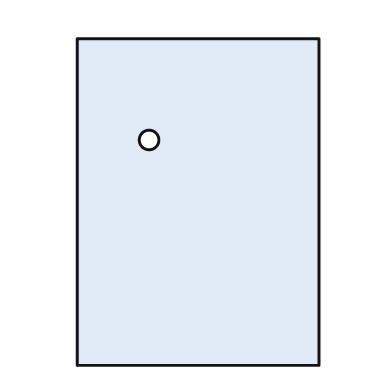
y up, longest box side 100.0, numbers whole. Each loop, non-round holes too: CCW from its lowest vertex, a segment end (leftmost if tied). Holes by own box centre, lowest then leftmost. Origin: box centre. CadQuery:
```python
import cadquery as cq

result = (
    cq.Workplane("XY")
    .moveTo(-37.0, -50.0)
    .lineTo(37.0, -50.0)
    .lineTo(37.0, 50.0)
    .lineTo(-37.0, 50.0)
    .close()
    .moveTo(-15.0, 19.0)
    .circle(3.0)
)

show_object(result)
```